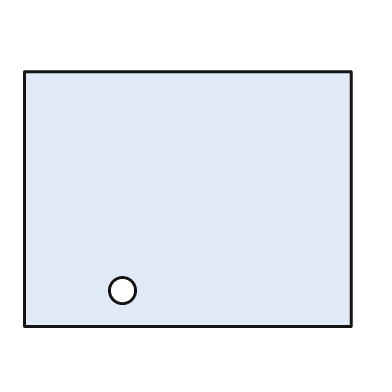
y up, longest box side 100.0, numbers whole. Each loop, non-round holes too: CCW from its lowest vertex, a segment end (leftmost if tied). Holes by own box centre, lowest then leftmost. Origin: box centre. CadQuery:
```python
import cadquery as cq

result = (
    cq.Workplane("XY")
    .moveTo(-50.0, -39.0)
    .lineTo(50.0, -39.0)
    .lineTo(50.0, 39.0)
    .lineTo(-50.0, 39.0)
    .close()
    .moveTo(-20.0, -28.0)
    .circle(4.0)
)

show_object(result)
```